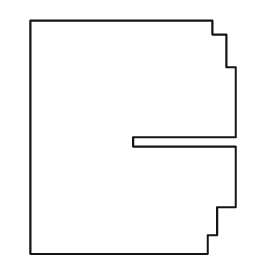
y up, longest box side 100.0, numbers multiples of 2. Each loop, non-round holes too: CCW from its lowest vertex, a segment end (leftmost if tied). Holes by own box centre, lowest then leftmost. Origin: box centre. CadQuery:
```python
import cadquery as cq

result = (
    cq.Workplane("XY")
    .moveTo(-44.0, -50.0)
    .lineTo(32.0, -50.0)
    .lineTo(32.0, -42.0)
    .lineTo(36.0, -42.0)
    .lineTo(36.0, -30.0)
    .lineTo(44.0, -30.0)
    .lineTo(44.0, -4.0)
    .lineTo(0.0, -4.0)
    .lineTo(0.0, 0.0)
    .lineTo(44.0, 0.0)
    .lineTo(44.0, 30.0)
    .lineTo(40.0, 30.0)
    .lineTo(40.0, 44.0)
    .lineTo(34.0, 44.0)
    .lineTo(34.0, 50.0)
    .lineTo(-44.0, 50.0)
    .close()
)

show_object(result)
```